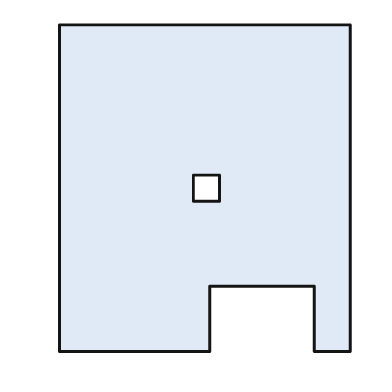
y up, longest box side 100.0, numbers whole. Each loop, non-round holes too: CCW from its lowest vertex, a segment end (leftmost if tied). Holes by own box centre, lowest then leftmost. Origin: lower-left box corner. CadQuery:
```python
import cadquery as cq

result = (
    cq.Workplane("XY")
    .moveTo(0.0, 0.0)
    .lineTo(46.0, 0.0)
    .lineTo(46.0, 20.0)
    .lineTo(78.0, 20.0)
    .lineTo(78.0, 0.0)
    .lineTo(89.0, 0.0)
    .lineTo(89.0, 100.0)
    .lineTo(0.0, 100.0)
    .close()
    .moveTo(41.0, 46.0)
    .lineTo(49.0, 46.0)
    .lineTo(49.0, 54.0)
    .lineTo(41.0, 54.0)
    .close()
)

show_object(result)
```